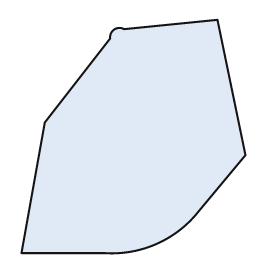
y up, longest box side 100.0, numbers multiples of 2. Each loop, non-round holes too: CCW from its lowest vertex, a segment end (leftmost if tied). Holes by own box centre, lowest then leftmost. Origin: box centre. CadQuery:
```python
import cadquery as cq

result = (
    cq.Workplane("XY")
    .moveTo(-48.0, -50.0)
    .lineTo(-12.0, -50.0)
    .threePointArc((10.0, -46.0), (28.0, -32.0))
    .lineTo(48.0, -8.0)
    .lineTo(36.0, 50.0)
    .lineTo(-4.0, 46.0)
    .threePointArc((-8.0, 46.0), (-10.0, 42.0))
    .lineTo(-38.0, 6.0)
    .close()
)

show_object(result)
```